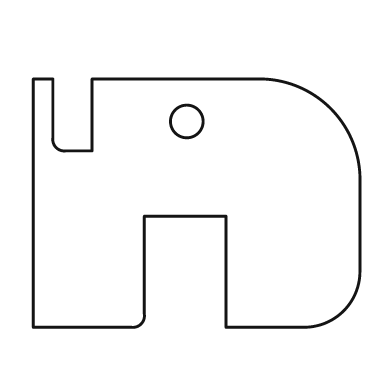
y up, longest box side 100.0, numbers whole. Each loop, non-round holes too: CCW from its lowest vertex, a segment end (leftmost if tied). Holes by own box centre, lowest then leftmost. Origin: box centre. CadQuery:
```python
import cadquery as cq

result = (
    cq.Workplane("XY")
    .moveTo(-50.0, -38.0)
    .lineTo(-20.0, -38.0)
    .threePointArc((-17.0, -37.0), (-16.0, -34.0))
    .lineTo(-16.0, -4.0)
    .lineTo(9.0, -4.0)
    .lineTo(9.0, -38.0)
    .lineTo(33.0, -38.0)
    .threePointArc((45.0, -33.0), (50.0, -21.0))
    .lineTo(50.0, 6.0)
    .threePointArc((41.0, 29.0), (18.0, 38.0))
    .lineTo(-32.0, 38.0)
    .lineTo(-32.0, 16.0)
    .lineTo(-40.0, 16.0)
    .threePointArc((-43.0, 17.0), (-44.0, 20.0))
    .lineTo(-44.0, 38.0)
    .lineTo(-50.0, 38.0)
    .close()
    .moveTo(-3.0, 25.0)
    .circle(5.0)
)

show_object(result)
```